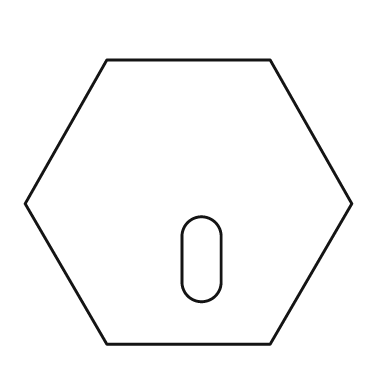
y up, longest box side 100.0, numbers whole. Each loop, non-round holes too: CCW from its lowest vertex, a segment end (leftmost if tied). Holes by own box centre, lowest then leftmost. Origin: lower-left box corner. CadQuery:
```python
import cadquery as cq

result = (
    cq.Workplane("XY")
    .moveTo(25.0, 0.0)
    .lineTo(75.0, 0.0)
    .lineTo(100.0, 43.0)
    .lineTo(75.0, 87.0)
    .lineTo(25.0, 87.0)
    .lineTo(0.0, 43.0)
    .close()
    .moveTo(48.0, 19.0)
    .threePointArc((54.0, 13.0), (60.0, 19.0))
    .lineTo(60.0, 33.0)
    .threePointArc((54.0, 39.0), (48.0, 33.0))
    .close()
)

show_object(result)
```